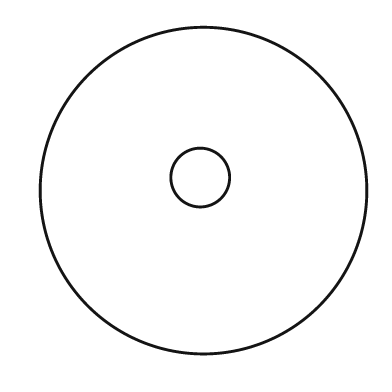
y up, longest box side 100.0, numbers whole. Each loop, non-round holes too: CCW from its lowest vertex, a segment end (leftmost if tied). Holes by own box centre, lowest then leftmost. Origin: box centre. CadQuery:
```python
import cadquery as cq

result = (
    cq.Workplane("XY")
    .moveTo(0.0, 0.0)
    .circle(50.0)
    .moveTo(-1.0, 4.0)
    .circle(9.0)
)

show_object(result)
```